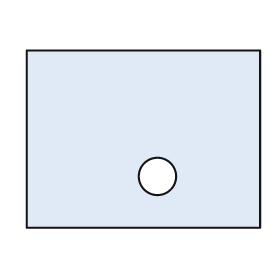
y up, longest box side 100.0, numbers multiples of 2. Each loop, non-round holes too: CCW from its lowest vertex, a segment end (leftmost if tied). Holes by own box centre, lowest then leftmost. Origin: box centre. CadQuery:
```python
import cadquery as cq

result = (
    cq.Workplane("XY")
    .moveTo(-50.0, -38.0)
    .lineTo(50.0, -38.0)
    .lineTo(50.0, 38.0)
    .lineTo(-50.0, 38.0)
    .close()
    .moveTo(6.0, -16.0)
    .circle(8.0)
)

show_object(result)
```